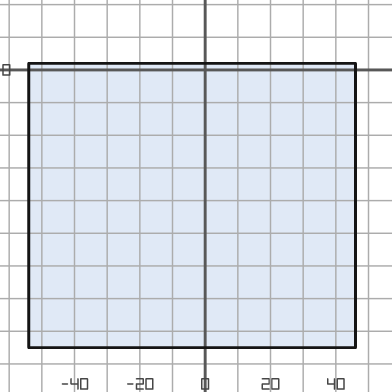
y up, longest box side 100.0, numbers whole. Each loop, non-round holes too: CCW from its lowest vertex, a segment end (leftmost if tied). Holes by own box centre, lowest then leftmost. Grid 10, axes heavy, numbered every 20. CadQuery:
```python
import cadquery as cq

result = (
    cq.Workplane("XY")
    .moveTo(-54.0, -85.0)
    .lineTo(46.0, -85.0)
    .lineTo(46.0, 2.0)
    .lineTo(-54.0, 2.0)
    .close()
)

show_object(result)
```